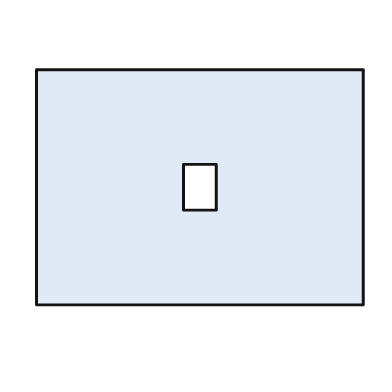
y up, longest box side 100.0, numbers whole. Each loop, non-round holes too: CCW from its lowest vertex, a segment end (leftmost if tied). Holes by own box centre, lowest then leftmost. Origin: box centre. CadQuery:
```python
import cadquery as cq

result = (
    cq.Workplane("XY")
    .moveTo(-50.0, -36.0)
    .lineTo(50.0, -36.0)
    .lineTo(50.0, 36.0)
    .lineTo(-50.0, 36.0)
    .close()
    .moveTo(-5.0, -7.0)
    .lineTo(5.0, -7.0)
    .lineTo(5.0, 7.0)
    .lineTo(-5.0, 7.0)
    .close()
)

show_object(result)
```